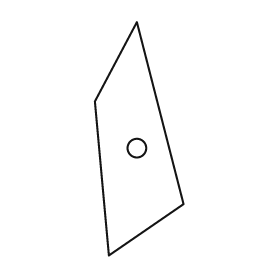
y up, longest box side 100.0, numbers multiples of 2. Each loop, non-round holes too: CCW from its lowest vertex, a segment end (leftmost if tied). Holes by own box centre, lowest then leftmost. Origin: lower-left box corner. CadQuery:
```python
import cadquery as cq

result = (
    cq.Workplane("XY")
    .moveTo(6.0, 0.0)
    .lineTo(38.0, 22.0)
    .lineTo(18.0, 100.0)
    .lineTo(0.0, 66.0)
    .close()
    .moveTo(18.0, 46.0)
    .circle(4.0)
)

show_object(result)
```